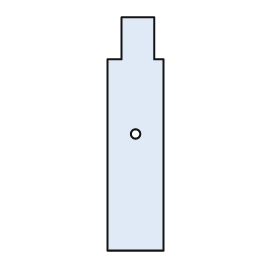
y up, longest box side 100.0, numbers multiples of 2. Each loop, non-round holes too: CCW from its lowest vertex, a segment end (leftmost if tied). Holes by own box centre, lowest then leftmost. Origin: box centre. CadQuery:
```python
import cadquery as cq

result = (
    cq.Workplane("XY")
    .moveTo(-12.0, -50.0)
    .lineTo(12.0, -50.0)
    .lineTo(12.0, 32.0)
    .lineTo(8.0, 32.0)
    .lineTo(8.0, 50.0)
    .lineTo(-6.0, 50.0)
    .lineTo(-6.0, 32.0)
    .lineTo(-12.0, 32.0)
    .close()
    .moveTo(0.0, 0.0)
    .circle(2.0)
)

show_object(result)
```